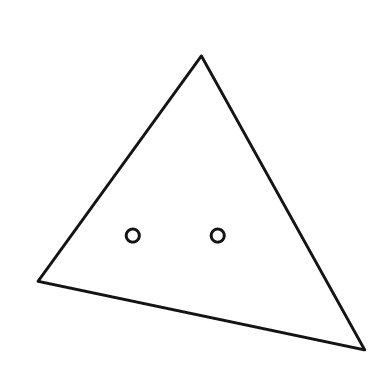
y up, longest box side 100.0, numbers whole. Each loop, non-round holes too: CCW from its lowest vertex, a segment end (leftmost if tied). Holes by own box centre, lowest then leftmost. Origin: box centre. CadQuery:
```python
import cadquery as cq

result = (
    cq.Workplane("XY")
    .moveTo(50.0, -45.0)
    .lineTo(0.0, 45.0)
    .lineTo(-50.0, -24.0)
    .close()
    .moveTo(-21.0, -10.0)
    .circle(2.0)
    .moveTo(5.0, -10.0)
    .circle(2.0)
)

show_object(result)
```